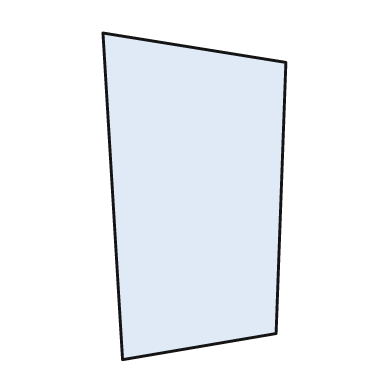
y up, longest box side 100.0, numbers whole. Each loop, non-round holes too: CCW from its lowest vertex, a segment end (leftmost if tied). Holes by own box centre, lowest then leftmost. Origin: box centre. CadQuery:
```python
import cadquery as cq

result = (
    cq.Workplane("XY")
    .moveTo(-22.0, -50.0)
    .lineTo(25.0, -42.0)
    .lineTo(28.0, 41.0)
    .lineTo(-28.0, 50.0)
    .close()
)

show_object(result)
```